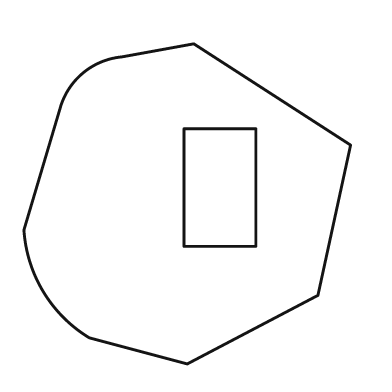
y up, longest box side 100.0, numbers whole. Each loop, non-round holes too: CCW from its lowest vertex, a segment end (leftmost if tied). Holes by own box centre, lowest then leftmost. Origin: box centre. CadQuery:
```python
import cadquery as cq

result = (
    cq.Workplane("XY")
    .moveTo(0.0, -49.0)
    .lineTo(40.0, -28.0)
    .lineTo(50.0, 18.0)
    .lineTo(2.0, 49.0)
    .lineTo(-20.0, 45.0)
    .threePointArc((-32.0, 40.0), (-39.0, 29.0))
    .lineTo(-50.0, -8.0)
    .threePointArc((-44.0, -27.0), (-30.0, -41.0))
    .close()
    .moveTo(-1.0, -13.0)
    .lineTo(21.0, -13.0)
    .lineTo(21.0, 23.0)
    .lineTo(-1.0, 23.0)
    .close()
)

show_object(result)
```